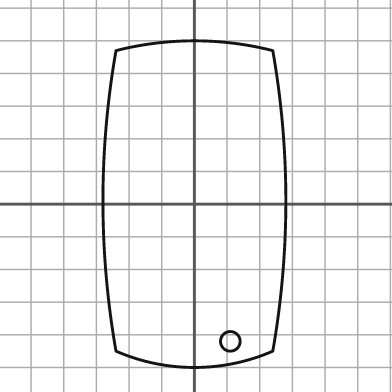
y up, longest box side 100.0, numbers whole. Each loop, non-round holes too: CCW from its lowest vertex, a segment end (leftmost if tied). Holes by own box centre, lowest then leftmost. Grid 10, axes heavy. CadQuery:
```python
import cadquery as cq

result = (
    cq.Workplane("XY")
    .moveTo(-24.0, -45.0)
    .threePointArc((0.0, -50.0), (24.0, -45.0))
    .threePointArc((28.0, 1.0), (24.0, 47.0))
    .threePointArc((0.0, 50.0), (-24.0, 47.0))
    .threePointArc((-28.0, 1.0), (-24.0, -45.0))
    .close()
    .moveTo(11.0, -42.0)
    .circle(3.0)
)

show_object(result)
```